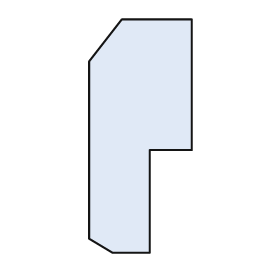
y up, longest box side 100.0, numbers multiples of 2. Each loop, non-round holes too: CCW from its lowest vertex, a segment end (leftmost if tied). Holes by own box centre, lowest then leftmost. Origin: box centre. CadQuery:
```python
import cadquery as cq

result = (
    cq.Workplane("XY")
    .moveTo(-12.0, -50.0)
    .lineTo(4.0, -50.0)
    .lineTo(4.0, -6.0)
    .lineTo(22.0, -6.0)
    .lineTo(22.0, 50.0)
    .lineTo(-8.0, 50.0)
    .lineTo(-22.0, 32.0)
    .lineTo(-22.0, -44.0)
    .close()
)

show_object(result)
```